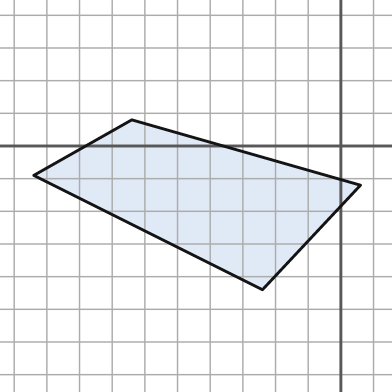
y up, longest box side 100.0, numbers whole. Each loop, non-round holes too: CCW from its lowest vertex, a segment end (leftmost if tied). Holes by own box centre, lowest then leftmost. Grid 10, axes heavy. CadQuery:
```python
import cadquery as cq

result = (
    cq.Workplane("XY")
    .moveTo(-24.0, -44.0)
    .lineTo(6.0, -12.0)
    .lineTo(-64.0, 8.0)
    .lineTo(-94.0, -9.0)
    .close()
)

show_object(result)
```